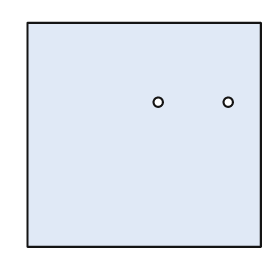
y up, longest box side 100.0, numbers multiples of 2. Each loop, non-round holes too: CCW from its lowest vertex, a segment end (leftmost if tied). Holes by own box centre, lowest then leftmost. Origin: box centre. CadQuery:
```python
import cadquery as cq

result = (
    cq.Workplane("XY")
    .moveTo(-50.0, -48.0)
    .lineTo(50.0, -48.0)
    .lineTo(50.0, 48.0)
    .lineTo(-50.0, 48.0)
    .close()
    .moveTo(6.0, 14.0)
    .circle(2.0)
    .moveTo(36.0, 14.0)
    .circle(2.0)
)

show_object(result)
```